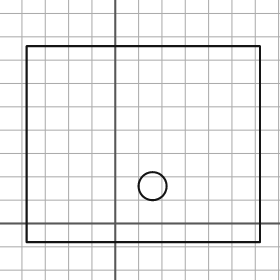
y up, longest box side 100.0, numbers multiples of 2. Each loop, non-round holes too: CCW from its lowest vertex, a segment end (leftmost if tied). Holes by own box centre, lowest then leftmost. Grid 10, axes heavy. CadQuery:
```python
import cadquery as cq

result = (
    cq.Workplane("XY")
    .moveTo(-38.0, -8.0)
    .lineTo(62.0, -8.0)
    .lineTo(62.0, 76.0)
    .lineTo(-38.0, 76.0)
    .close()
    .moveTo(16.0, 16.0)
    .circle(6.0)
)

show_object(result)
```